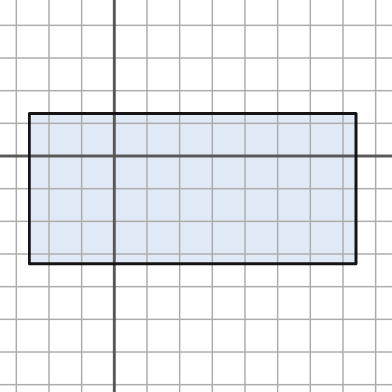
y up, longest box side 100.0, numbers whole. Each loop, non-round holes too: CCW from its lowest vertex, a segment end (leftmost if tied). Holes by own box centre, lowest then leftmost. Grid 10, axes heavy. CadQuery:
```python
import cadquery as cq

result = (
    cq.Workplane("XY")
    .moveTo(-26.0, -33.0)
    .lineTo(74.0, -33.0)
    .lineTo(74.0, 13.0)
    .lineTo(-26.0, 13.0)
    .close()
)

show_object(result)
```